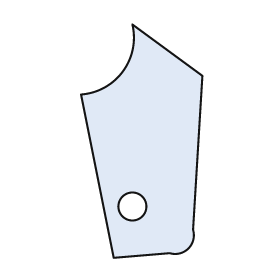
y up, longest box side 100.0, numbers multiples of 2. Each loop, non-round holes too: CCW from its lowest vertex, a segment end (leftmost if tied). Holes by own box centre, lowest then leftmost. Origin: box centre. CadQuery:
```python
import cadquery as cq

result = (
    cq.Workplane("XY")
    .moveTo(-12.0, -50.0)
    .lineTo(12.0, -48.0)
    .threePointArc((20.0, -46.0), (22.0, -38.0))
    .lineTo(26.0, 28.0)
    .lineTo(-4.0, 50.0)
    .threePointArc((-8.0, 30.0), (-26.0, 20.0))
    .close()
    .moveTo(-4.0, -28.0)
    .circle(6.0)
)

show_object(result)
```